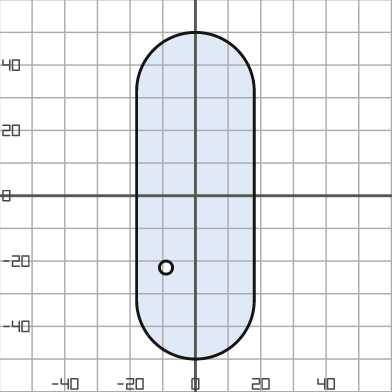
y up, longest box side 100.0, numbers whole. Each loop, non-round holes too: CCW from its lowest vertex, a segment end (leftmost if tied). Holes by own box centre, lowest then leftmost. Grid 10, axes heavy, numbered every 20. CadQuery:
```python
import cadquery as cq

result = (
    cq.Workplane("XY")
    .moveTo(-18.0, -32.0)
    .threePointArc((0.0, -50.0), (18.0, -32.0))
    .lineTo(18.0, 32.0)
    .threePointArc((0.0, 50.0), (-18.0, 32.0))
    .close()
    .moveTo(-9.0, -22.0)
    .circle(2.0)
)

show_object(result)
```